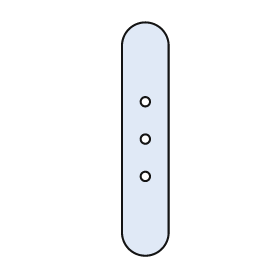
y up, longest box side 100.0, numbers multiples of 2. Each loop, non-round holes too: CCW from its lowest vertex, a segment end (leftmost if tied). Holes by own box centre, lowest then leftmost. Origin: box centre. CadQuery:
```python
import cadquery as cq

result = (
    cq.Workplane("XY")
    .moveTo(-10.0, -40.0)
    .threePointArc((0.0, -50.0), (10.0, -40.0))
    .lineTo(10.0, 40.0)
    .threePointArc((0.0, 50.0), (-10.0, 40.0))
    .close()
    .moveTo(0.0, -16.0)
    .circle(2.0)
    .moveTo(0.0, 0.0)
    .circle(2.0)
    .moveTo(0.0, 16.0)
    .circle(2.0)
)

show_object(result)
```